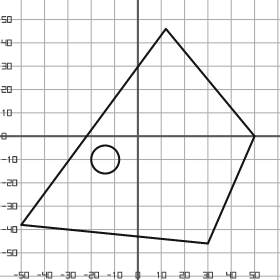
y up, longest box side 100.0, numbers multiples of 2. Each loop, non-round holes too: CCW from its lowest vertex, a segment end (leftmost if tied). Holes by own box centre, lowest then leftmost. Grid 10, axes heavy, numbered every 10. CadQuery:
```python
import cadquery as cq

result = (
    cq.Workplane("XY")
    .moveTo(30.0, -46.0)
    .lineTo(50.0, 0.0)
    .lineTo(12.0, 46.0)
    .lineTo(-50.0, -38.0)
    .close()
    .moveTo(-14.0, -10.0)
    .circle(6.0)
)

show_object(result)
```